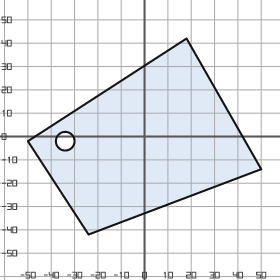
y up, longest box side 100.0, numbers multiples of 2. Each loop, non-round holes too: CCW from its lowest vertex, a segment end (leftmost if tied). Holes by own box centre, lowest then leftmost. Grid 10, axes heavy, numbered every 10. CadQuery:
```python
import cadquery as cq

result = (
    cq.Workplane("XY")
    .moveTo(-24.0, -42.0)
    .lineTo(50.0, -14.0)
    .lineTo(18.0, 42.0)
    .lineTo(-50.0, -2.0)
    .close()
    .moveTo(-34.0, -2.0)
    .circle(4.0)
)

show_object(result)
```